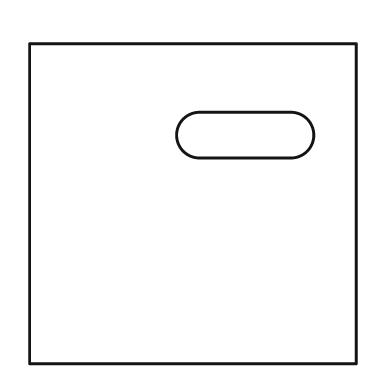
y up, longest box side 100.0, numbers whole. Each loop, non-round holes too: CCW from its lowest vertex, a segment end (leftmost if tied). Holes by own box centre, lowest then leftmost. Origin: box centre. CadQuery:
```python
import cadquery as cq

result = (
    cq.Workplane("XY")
    .moveTo(-50.0, -49.0)
    .lineTo(50.0, -49.0)
    .lineTo(50.0, 49.0)
    .lineTo(-50.0, 49.0)
    .close()
    .moveTo(2.0, 14.0)
    .lineTo(30.0, 14.0)
    .threePointArc((37.0, 21.0), (30.0, 28.0))
    .lineTo(2.0, 28.0)
    .threePointArc((-5.0, 21.0), (2.0, 14.0))
    .close()
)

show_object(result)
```